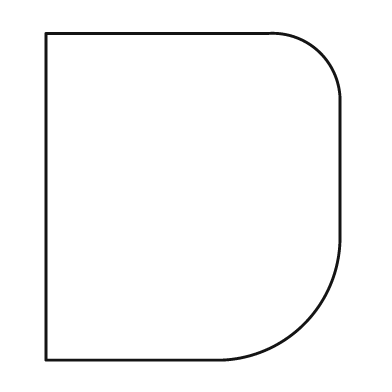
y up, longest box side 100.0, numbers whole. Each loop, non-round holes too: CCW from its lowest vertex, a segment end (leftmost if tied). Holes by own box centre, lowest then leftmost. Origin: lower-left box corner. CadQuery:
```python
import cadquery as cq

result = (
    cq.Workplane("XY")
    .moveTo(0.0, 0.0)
    .lineTo(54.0, 0.0)
    .threePointArc((79.0, 11.0), (90.0, 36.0))
    .lineTo(90.0, 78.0)
    .threePointArc((84.0, 94.0), (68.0, 100.0))
    .lineTo(0.0, 100.0)
    .close()
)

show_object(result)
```